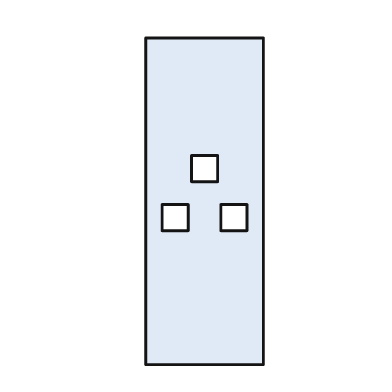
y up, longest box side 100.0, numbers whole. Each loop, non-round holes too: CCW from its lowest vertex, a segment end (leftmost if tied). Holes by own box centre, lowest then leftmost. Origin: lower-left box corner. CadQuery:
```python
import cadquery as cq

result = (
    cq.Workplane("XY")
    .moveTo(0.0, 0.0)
    .lineTo(36.0, 0.0)
    .lineTo(36.0, 100.0)
    .lineTo(0.0, 100.0)
    .close()
    .moveTo(5.0, 41.0)
    .lineTo(13.0, 41.0)
    .lineTo(13.0, 49.0)
    .lineTo(5.0, 49.0)
    .close()
    .moveTo(23.0, 41.0)
    .lineTo(31.0, 41.0)
    .lineTo(31.0, 49.0)
    .lineTo(23.0, 49.0)
    .close()
    .moveTo(14.0, 56.0)
    .lineTo(22.0, 56.0)
    .lineTo(22.0, 64.0)
    .lineTo(14.0, 64.0)
    .close()
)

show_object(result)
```